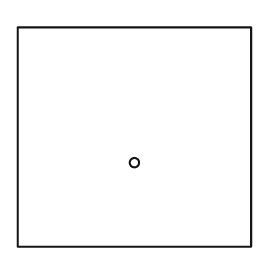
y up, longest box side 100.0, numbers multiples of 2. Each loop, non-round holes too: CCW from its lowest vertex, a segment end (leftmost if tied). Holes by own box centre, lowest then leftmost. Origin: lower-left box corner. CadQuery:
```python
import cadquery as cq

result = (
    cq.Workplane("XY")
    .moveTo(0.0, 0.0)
    .lineTo(100.0, 0.0)
    .lineTo(100.0, 94.0)
    .lineTo(0.0, 94.0)
    .close()
    .moveTo(50.0, 36.0)
    .circle(2.0)
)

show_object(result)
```